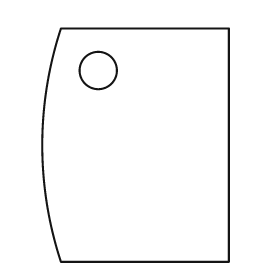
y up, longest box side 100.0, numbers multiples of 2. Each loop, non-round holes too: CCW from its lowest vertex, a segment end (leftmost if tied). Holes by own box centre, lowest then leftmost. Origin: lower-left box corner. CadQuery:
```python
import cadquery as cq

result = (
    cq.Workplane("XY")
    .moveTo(8.0, 0.0)
    .lineTo(80.0, 0.0)
    .lineTo(80.0, 100.0)
    .lineTo(8.0, 100.0)
    .threePointArc((0.0, 50.0), (8.0, 0.0))
    .close()
    .moveTo(24.0, 82.0)
    .circle(8.0)
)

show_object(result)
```